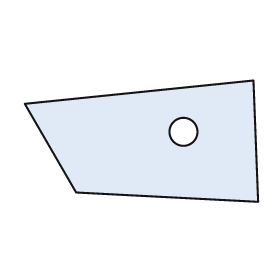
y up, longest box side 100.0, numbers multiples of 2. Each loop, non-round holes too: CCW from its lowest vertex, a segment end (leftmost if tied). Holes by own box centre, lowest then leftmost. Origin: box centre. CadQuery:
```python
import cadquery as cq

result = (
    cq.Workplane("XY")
    .moveTo(50.0, -26.0)
    .lineTo(48.0, 26.0)
    .lineTo(-50.0, 16.0)
    .lineTo(-28.0, -22.0)
    .close()
    .moveTo(18.0, 4.0)
    .circle(6.0)
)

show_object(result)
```